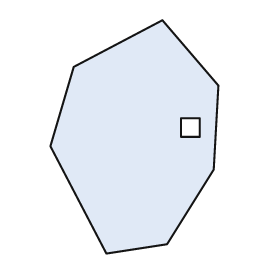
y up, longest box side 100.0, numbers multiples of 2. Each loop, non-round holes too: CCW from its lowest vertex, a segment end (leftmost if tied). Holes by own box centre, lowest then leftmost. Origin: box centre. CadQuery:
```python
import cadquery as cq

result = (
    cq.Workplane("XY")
    .moveTo(-12.0, -50.0)
    .lineTo(14.0, -46.0)
    .lineTo(34.0, -14.0)
    .lineTo(36.0, 22.0)
    .lineTo(12.0, 50.0)
    .lineTo(-26.0, 30.0)
    .lineTo(-36.0, -4.0)
    .close()
    .moveTo(20.0, 0.0)
    .lineTo(28.0, 0.0)
    .lineTo(28.0, 8.0)
    .lineTo(20.0, 8.0)
    .close()
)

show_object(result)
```